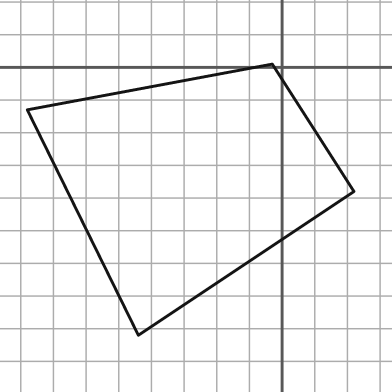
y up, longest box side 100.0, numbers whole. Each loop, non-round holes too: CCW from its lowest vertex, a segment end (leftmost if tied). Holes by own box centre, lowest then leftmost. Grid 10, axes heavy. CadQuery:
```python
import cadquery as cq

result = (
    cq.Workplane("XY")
    .moveTo(-44.0, -82.0)
    .lineTo(22.0, -38.0)
    .lineTo(-3.0, 1.0)
    .lineTo(-78.0, -13.0)
    .close()
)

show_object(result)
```